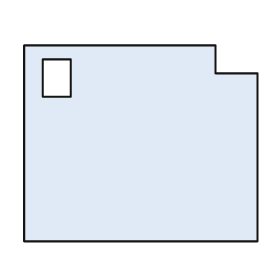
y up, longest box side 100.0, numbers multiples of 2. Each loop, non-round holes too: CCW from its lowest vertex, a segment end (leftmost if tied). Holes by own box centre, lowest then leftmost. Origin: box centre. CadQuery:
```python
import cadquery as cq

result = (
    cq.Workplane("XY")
    .moveTo(-50.0, -42.0)
    .lineTo(50.0, -42.0)
    .lineTo(50.0, 30.0)
    .lineTo(32.0, 30.0)
    .lineTo(32.0, 42.0)
    .lineTo(-50.0, 42.0)
    .close()
    .moveTo(-42.0, 20.0)
    .lineTo(-30.0, 20.0)
    .lineTo(-30.0, 36.0)
    .lineTo(-42.0, 36.0)
    .close()
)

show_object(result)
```